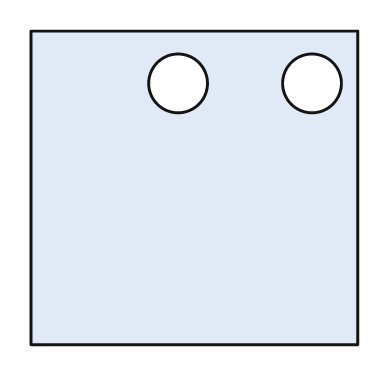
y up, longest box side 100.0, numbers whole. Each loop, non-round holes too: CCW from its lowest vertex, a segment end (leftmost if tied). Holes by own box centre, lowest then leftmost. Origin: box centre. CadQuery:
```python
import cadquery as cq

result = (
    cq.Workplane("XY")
    .moveTo(-50.0, -48.0)
    .lineTo(50.0, -48.0)
    .lineTo(50.0, 48.0)
    .lineTo(-50.0, 48.0)
    .close()
    .moveTo(-5.0, 32.0)
    .circle(9.0)
    .moveTo(36.0, 32.0)
    .circle(9.0)
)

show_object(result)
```